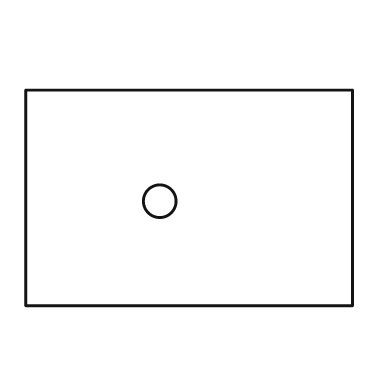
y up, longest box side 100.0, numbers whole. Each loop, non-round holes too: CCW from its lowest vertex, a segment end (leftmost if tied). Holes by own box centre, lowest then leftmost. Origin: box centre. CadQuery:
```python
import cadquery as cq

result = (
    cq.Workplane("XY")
    .moveTo(-50.0, -33.0)
    .lineTo(50.0, -33.0)
    .lineTo(50.0, 33.0)
    .lineTo(-50.0, 33.0)
    .close()
    .moveTo(-9.0, -1.0)
    .circle(5.0)
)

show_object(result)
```